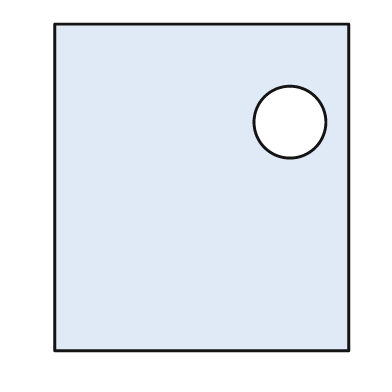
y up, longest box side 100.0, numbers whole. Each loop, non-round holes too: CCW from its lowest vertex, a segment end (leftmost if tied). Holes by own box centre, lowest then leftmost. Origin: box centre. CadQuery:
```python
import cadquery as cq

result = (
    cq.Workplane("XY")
    .moveTo(-45.0, -50.0)
    .lineTo(45.0, -50.0)
    .lineTo(45.0, 50.0)
    .lineTo(-45.0, 50.0)
    .close()
    .moveTo(27.0, 20.0)
    .circle(11.0)
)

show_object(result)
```